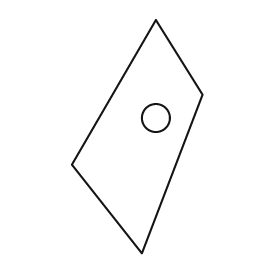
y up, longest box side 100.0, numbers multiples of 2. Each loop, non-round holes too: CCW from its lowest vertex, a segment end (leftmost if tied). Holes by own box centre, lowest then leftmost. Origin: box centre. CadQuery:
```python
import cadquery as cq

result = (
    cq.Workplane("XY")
    .moveTo(2.0, -50.0)
    .lineTo(28.0, 18.0)
    .lineTo(8.0, 50.0)
    .lineTo(-28.0, -12.0)
    .close()
    .moveTo(8.0, 8.0)
    .circle(6.0)
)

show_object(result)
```